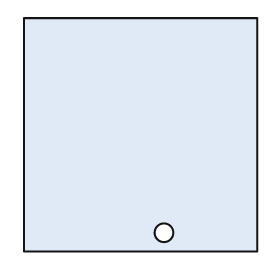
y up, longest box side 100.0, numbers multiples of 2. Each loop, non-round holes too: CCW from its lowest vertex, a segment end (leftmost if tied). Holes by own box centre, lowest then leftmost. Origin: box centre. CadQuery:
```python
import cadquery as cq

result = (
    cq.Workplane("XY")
    .moveTo(-50.0, -50.0)
    .lineTo(50.0, -50.0)
    .lineTo(50.0, 50.0)
    .lineTo(-50.0, 50.0)
    .close()
    .moveTo(10.0, -42.0)
    .circle(4.0)
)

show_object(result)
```